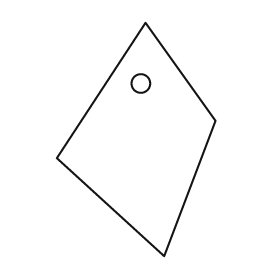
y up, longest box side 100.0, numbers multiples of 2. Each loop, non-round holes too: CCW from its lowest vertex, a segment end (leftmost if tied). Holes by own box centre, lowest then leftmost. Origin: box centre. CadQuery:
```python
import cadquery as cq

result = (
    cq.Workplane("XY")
    .moveTo(12.0, -50.0)
    .lineTo(34.0, 8.0)
    .lineTo(4.0, 50.0)
    .lineTo(-34.0, -8.0)
    .close()
    .moveTo(2.0, 24.0)
    .circle(4.0)
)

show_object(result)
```